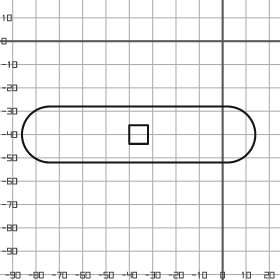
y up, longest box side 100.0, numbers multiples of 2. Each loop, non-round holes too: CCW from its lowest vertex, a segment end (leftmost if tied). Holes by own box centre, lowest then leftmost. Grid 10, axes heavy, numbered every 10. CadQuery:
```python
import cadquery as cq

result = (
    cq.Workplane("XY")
    .moveTo(-74.0, -52.0)
    .lineTo(2.0, -52.0)
    .threePointArc((14.0, -40.0), (2.0, -28.0))
    .lineTo(-74.0, -28.0)
    .threePointArc((-86.0, -40.0), (-74.0, -52.0))
    .close()
    .moveTo(-40.0, -44.0)
    .lineTo(-32.0, -44.0)
    .lineTo(-32.0, -36.0)
    .lineTo(-40.0, -36.0)
    .close()
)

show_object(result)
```